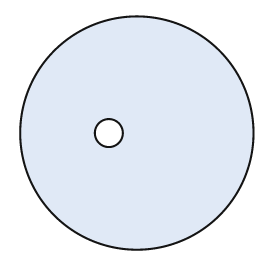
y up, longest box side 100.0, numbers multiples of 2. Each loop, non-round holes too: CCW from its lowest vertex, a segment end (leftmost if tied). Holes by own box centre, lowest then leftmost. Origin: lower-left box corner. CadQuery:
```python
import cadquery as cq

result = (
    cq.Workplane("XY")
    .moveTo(50.0, 50.0)
    .circle(50.0)
    .moveTo(38.0, 50.0)
    .circle(6.0)
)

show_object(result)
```